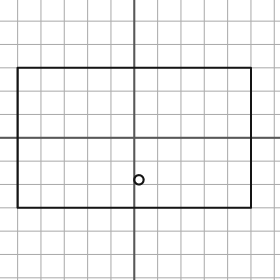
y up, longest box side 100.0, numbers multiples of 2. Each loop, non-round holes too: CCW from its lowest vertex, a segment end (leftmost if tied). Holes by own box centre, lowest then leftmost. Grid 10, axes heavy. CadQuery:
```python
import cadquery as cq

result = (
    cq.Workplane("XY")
    .moveTo(-50.0, -30.0)
    .lineTo(50.0, -30.0)
    .lineTo(50.0, 30.0)
    .lineTo(-50.0, 30.0)
    .close()
    .moveTo(2.0, -18.0)
    .circle(2.0)
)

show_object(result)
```